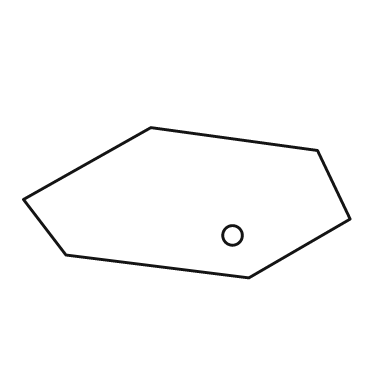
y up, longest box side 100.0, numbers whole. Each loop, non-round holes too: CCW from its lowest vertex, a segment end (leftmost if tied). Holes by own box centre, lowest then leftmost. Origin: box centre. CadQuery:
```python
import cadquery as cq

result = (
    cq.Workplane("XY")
    .moveTo(19.0, -23.0)
    .lineTo(50.0, -5.0)
    .lineTo(40.0, 16.0)
    .lineTo(-11.0, 23.0)
    .lineTo(-50.0, 1.0)
    .lineTo(-37.0, -16.0)
    .close()
    .moveTo(14.0, -10.0)
    .circle(3.0)
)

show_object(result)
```